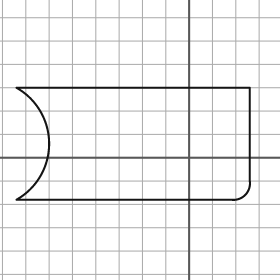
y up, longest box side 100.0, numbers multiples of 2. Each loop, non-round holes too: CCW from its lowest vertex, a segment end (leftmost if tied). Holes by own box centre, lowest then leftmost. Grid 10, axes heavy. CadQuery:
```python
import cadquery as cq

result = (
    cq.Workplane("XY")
    .moveTo(-74.0, -18.0)
    .lineTo(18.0, -18.0)
    .threePointArc((24.0, -16.0), (26.0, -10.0))
    .lineTo(26.0, 30.0)
    .lineTo(-74.0, 30.0)
    .threePointArc((-60.0, 6.0), (-74.0, -18.0))
    .close()
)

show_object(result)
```